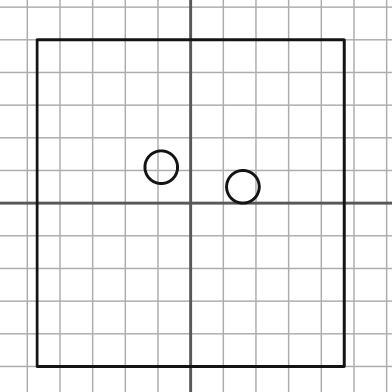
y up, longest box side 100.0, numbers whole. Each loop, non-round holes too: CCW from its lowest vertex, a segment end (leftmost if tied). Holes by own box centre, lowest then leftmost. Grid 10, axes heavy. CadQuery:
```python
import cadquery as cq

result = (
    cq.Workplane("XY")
    .moveTo(-47.0, -50.0)
    .lineTo(47.0, -50.0)
    .lineTo(47.0, 50.0)
    .lineTo(-47.0, 50.0)
    .close()
    .moveTo(16.0, 5.0)
    .circle(5.0)
    .moveTo(-9.0, 11.0)
    .circle(5.0)
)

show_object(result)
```